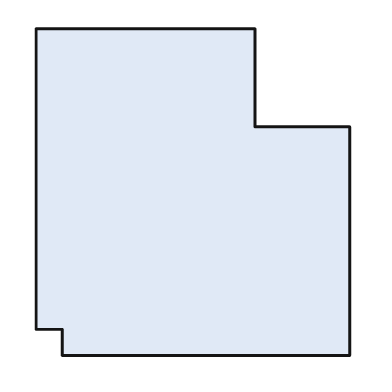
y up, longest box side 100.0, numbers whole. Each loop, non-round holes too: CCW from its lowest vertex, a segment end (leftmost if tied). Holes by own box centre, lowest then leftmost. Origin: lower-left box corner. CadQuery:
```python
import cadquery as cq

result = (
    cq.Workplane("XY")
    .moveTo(8.0, 0.0)
    .lineTo(96.0, 0.0)
    .lineTo(96.0, 70.0)
    .lineTo(67.0, 70.0)
    .lineTo(67.0, 100.0)
    .lineTo(0.0, 100.0)
    .lineTo(0.0, 8.0)
    .lineTo(8.0, 8.0)
    .close()
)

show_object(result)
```